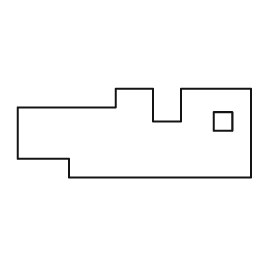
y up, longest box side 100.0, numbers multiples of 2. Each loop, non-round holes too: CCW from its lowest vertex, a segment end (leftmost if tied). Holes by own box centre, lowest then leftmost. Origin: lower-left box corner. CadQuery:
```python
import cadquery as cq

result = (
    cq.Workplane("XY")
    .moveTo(22.0, 0.0)
    .lineTo(100.0, 0.0)
    .lineTo(100.0, 38.0)
    .lineTo(70.0, 38.0)
    .lineTo(70.0, 24.0)
    .lineTo(58.0, 24.0)
    .lineTo(58.0, 38.0)
    .lineTo(42.0, 38.0)
    .lineTo(42.0, 30.0)
    .lineTo(0.0, 30.0)
    .lineTo(0.0, 8.0)
    .lineTo(22.0, 8.0)
    .close()
    .moveTo(84.0, 20.0)
    .lineTo(92.0, 20.0)
    .lineTo(92.0, 28.0)
    .lineTo(84.0, 28.0)
    .close()
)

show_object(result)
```